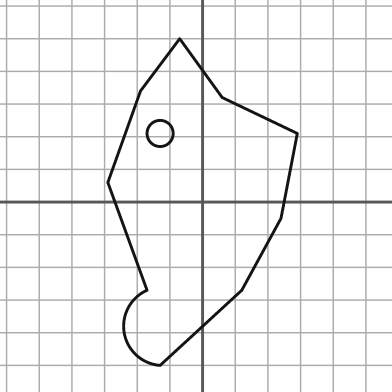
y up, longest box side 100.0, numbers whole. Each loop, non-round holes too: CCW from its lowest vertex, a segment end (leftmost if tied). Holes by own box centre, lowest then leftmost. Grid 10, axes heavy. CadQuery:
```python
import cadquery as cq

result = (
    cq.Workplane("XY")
    .moveTo(-13.0, -50.0)
    .lineTo(12.0, -27.0)
    .lineTo(24.0, -5.0)
    .lineTo(29.0, 21.0)
    .lineTo(6.0, 32.0)
    .lineTo(-7.0, 50.0)
    .lineTo(-19.0, 34.0)
    .lineTo(-29.0, 6.0)
    .lineTo(-17.0, -27.0)
    .threePointArc((-24.0, -40.0), (-13.0, -50.0))
    .close()
    .moveTo(-13.0, 21.0)
    .circle(4.0)
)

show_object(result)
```